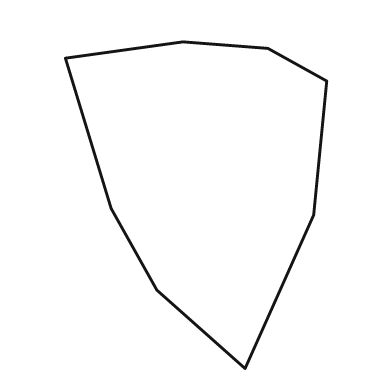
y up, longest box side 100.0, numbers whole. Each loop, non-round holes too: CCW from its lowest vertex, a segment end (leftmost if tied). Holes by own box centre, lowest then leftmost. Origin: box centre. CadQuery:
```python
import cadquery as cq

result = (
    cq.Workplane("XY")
    .moveTo(15.0, -50.0)
    .lineTo(36.0, -3.0)
    .lineTo(40.0, 38.0)
    .lineTo(22.0, 48.0)
    .lineTo(-4.0, 50.0)
    .lineTo(-40.0, 45.0)
    .lineTo(-26.0, -1.0)
    .lineTo(-12.0, -26.0)
    .close()
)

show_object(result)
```